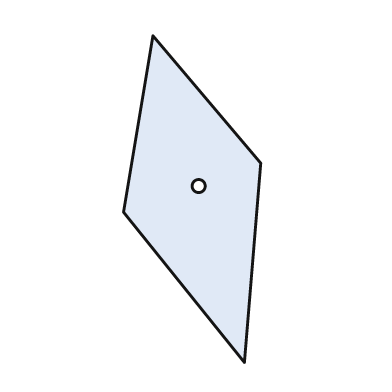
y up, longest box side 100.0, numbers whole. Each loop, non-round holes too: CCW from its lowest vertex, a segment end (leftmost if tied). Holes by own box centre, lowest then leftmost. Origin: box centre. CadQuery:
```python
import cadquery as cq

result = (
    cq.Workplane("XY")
    .moveTo(16.0, -50.0)
    .lineTo(21.0, 11.0)
    .lineTo(-12.0, 50.0)
    .lineTo(-21.0, -4.0)
    .close()
    .moveTo(2.0, 4.0)
    .circle(2.0)
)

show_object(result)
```